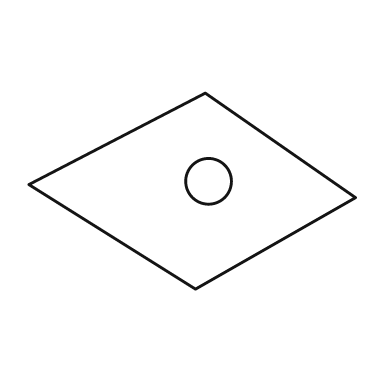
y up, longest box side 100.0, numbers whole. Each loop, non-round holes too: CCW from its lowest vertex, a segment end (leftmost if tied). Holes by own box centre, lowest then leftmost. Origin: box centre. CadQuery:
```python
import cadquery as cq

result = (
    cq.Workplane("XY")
    .moveTo(1.0, -30.0)
    .lineTo(50.0, -2.0)
    .lineTo(4.0, 30.0)
    .lineTo(-50.0, 2.0)
    .close()
    .moveTo(5.0, 3.0)
    .circle(7.0)
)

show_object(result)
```